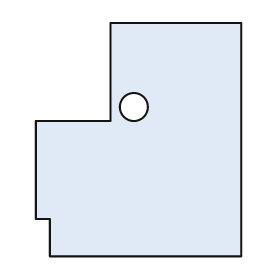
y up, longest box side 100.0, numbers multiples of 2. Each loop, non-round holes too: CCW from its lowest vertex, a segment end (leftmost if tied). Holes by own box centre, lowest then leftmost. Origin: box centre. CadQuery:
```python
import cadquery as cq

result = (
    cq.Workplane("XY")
    .moveTo(-38.0, -50.0)
    .lineTo(44.0, -50.0)
    .lineTo(44.0, 50.0)
    .lineTo(-12.0, 50.0)
    .lineTo(-12.0, 8.0)
    .lineTo(-44.0, 8.0)
    .lineTo(-44.0, -34.0)
    .lineTo(-38.0, -34.0)
    .close()
    .moveTo(-2.0, 14.0)
    .circle(6.0)
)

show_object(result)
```